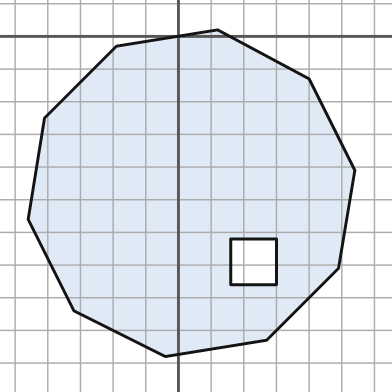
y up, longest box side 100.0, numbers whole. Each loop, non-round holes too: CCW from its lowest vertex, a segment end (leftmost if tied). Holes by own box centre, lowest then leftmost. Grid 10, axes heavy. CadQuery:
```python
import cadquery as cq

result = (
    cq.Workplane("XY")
    .moveTo(-4.0, -98.0)
    .lineTo(27.0, -93.0)
    .lineTo(49.0, -71.0)
    .lineTo(54.0, -41.0)
    .lineTo(40.0, -13.0)
    .lineTo(12.0, 2.0)
    .lineTo(-19.0, -3.0)
    .lineTo(-41.0, -25.0)
    .lineTo(-46.0, -56.0)
    .lineTo(-32.0, -84.0)
    .close()
    .moveTo(16.0, -76.0)
    .lineTo(30.0, -76.0)
    .lineTo(30.0, -62.0)
    .lineTo(16.0, -62.0)
    .close()
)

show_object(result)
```